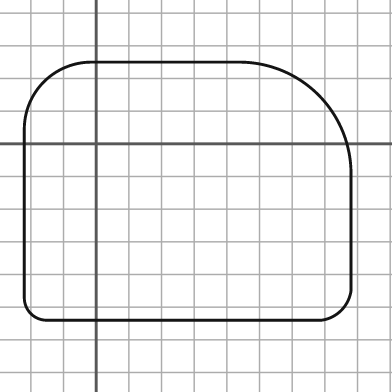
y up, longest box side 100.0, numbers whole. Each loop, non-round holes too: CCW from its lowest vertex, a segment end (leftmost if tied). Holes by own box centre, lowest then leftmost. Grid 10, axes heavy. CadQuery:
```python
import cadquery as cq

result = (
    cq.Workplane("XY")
    .moveTo(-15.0, -54.0)
    .lineTo(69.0, -54.0)
    .threePointArc((75.0, -51.0), (78.0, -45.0))
    .lineTo(78.0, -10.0)
    .threePointArc((68.0, 15.0), (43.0, 25.0))
    .lineTo(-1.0, 25.0)
    .threePointArc((-16.0, 19.0), (-22.0, 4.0))
    .lineTo(-22.0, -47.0)
    .threePointArc((-20.0, -52.0), (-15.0, -54.0))
    .close()
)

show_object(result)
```